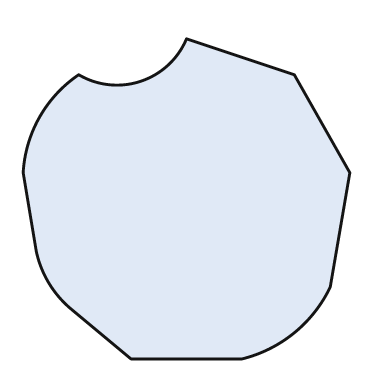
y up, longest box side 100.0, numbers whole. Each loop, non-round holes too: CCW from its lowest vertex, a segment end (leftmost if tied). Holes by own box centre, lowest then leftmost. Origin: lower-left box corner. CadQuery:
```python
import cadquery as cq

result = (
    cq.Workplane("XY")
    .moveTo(33.0, 0.0)
    .lineTo(67.0, 0.0)
    .threePointArc((83.0, 8.0), (94.0, 22.0))
    .lineTo(100.0, 57.0)
    .lineTo(83.0, 87.0)
    .lineTo(50.0, 98.0)
    .threePointArc((36.0, 85.0), (17.0, 87.0))
    .threePointArc((5.0, 74.0), (0.0, 57.0))
    .lineTo(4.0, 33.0)
    .threePointArc((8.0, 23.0), (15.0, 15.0))
    .close()
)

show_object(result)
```